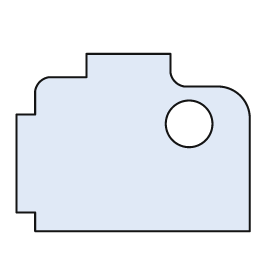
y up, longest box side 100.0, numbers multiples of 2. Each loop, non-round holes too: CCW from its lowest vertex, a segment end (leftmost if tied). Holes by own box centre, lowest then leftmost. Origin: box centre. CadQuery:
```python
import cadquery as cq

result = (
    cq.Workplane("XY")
    .moveTo(-42.0, -38.0)
    .lineTo(50.0, -38.0)
    .lineTo(50.0, 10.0)
    .threePointArc((46.0, 20.0), (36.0, 24.0))
    .lineTo(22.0, 24.0)
    .threePointArc((18.0, 26.0), (16.0, 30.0))
    .lineTo(16.0, 38.0)
    .lineTo(-20.0, 38.0)
    .lineTo(-20.0, 28.0)
    .lineTo(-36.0, 28.0)
    .threePointArc((-40.0, 26.0), (-42.0, 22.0))
    .lineTo(-42.0, 12.0)
    .lineTo(-50.0, 12.0)
    .lineTo(-50.0, -30.0)
    .lineTo(-42.0, -30.0)
    .close()
    .moveTo(24.0, 8.0)
    .circle(10.0)
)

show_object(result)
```